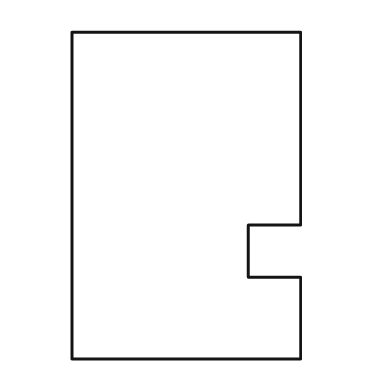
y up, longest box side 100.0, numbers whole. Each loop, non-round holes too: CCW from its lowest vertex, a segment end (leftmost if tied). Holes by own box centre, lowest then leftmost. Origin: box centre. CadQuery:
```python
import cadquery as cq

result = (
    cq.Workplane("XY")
    .moveTo(-35.0, -50.0)
    .lineTo(35.0, -50.0)
    .lineTo(35.0, -25.0)
    .lineTo(19.0, -25.0)
    .lineTo(19.0, -9.0)
    .lineTo(35.0, -9.0)
    .lineTo(35.0, 50.0)
    .lineTo(-35.0, 50.0)
    .close()
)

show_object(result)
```